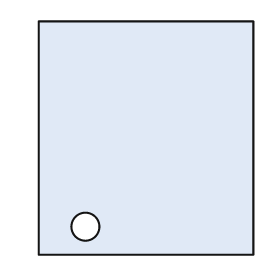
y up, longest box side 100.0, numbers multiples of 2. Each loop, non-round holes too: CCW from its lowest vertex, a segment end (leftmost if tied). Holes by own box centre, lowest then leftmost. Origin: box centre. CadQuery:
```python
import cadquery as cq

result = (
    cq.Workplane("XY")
    .moveTo(-46.0, -50.0)
    .lineTo(46.0, -50.0)
    .lineTo(46.0, 50.0)
    .lineTo(-46.0, 50.0)
    .close()
    .moveTo(-26.0, -38.0)
    .circle(6.0)
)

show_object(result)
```